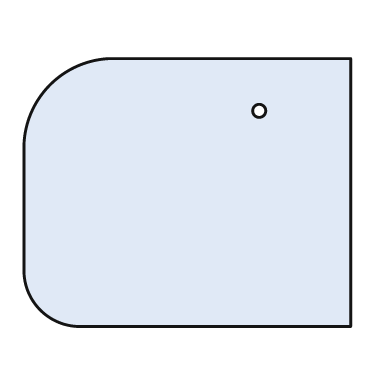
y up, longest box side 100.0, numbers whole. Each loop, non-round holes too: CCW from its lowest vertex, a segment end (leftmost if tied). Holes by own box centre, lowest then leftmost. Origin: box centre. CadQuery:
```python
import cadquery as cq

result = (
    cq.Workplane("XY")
    .moveTo(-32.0, -41.0)
    .lineTo(50.0, -41.0)
    .lineTo(50.0, 41.0)
    .lineTo(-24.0, 41.0)
    .threePointArc((-42.0, 33.0), (-50.0, 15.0))
    .lineTo(-50.0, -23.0)
    .threePointArc((-45.0, -36.0), (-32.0, -41.0))
    .close()
    .moveTo(22.0, 25.0)
    .circle(2.0)
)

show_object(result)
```